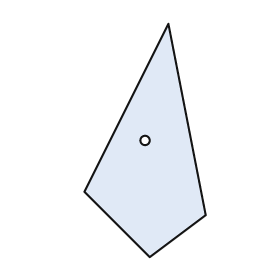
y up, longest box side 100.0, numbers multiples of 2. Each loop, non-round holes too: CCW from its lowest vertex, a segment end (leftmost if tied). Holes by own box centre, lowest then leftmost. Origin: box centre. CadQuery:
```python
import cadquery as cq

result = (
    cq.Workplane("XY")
    .moveTo(2.0, -50.0)
    .lineTo(26.0, -32.0)
    .lineTo(10.0, 50.0)
    .lineTo(-26.0, -22.0)
    .close()
    .moveTo(0.0, 0.0)
    .circle(2.0)
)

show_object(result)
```